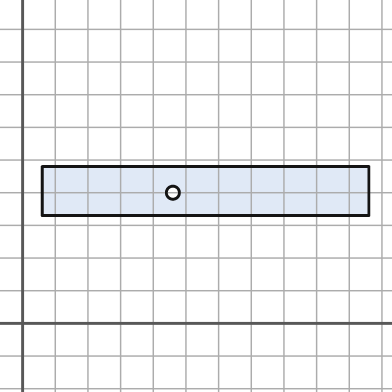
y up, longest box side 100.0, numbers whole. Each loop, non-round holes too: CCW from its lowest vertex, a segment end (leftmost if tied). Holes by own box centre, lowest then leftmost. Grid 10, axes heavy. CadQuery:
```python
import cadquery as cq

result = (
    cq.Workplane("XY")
    .moveTo(6.0, 33.0)
    .lineTo(106.0, 33.0)
    .lineTo(106.0, 48.0)
    .lineTo(6.0, 48.0)
    .close()
    .moveTo(46.0, 40.0)
    .circle(2.0)
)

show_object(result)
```